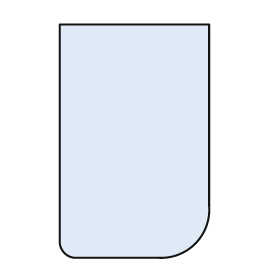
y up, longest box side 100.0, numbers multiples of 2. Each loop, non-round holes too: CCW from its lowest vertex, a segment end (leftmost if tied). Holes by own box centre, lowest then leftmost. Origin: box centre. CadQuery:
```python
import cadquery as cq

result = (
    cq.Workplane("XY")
    .moveTo(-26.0, -50.0)
    .lineTo(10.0, -50.0)
    .threePointArc((26.0, -44.0), (32.0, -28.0))
    .lineTo(32.0, 50.0)
    .lineTo(-32.0, 50.0)
    .lineTo(-32.0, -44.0)
    .threePointArc((-30.0, -48.0), (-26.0, -50.0))
    .close()
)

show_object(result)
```